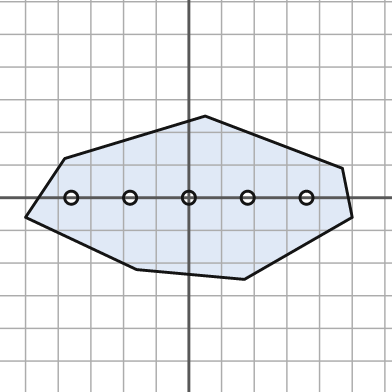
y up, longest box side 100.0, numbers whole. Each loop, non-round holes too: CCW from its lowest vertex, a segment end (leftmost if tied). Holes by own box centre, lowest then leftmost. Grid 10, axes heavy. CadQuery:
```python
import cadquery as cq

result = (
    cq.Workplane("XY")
    .moveTo(17.0, -25.0)
    .lineTo(50.0, -6.0)
    .lineTo(47.0, 9.0)
    .lineTo(5.0, 25.0)
    .lineTo(-38.0, 12.0)
    .lineTo(-50.0, -6.0)
    .lineTo(-16.0, -22.0)
    .close()
    .moveTo(-36.0, 0.0)
    .circle(2.0)
    .moveTo(-18.0, 0.0)
    .circle(2.0)
    .moveTo(0.0, 0.0)
    .circle(2.0)
    .moveTo(18.0, 0.0)
    .circle(2.0)
    .moveTo(36.0, 0.0)
    .circle(2.0)
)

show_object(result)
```